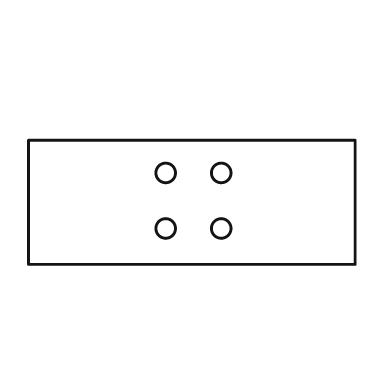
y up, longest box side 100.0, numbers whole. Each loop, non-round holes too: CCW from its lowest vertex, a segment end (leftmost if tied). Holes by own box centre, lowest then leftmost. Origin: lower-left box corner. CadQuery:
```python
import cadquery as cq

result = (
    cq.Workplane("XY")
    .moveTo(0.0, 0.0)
    .lineTo(100.0, 0.0)
    .lineTo(100.0, 38.0)
    .lineTo(0.0, 38.0)
    .close()
    .moveTo(42.0, 11.0)
    .circle(3.0)
    .moveTo(59.0, 11.0)
    .circle(3.0)
    .moveTo(42.0, 28.0)
    .circle(3.0)
    .moveTo(59.0, 28.0)
    .circle(3.0)
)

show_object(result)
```